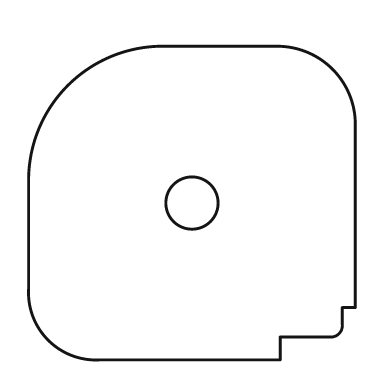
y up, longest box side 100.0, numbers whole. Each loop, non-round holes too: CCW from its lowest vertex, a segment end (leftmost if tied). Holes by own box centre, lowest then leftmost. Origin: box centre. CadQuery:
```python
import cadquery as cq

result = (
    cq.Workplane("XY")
    .moveTo(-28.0, -48.0)
    .lineTo(27.0, -48.0)
    .lineTo(27.0, -41.0)
    .lineTo(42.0, -41.0)
    .threePointArc((45.0, -40.0), (46.0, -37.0))
    .lineTo(46.0, -32.0)
    .lineTo(50.0, -32.0)
    .lineTo(50.0, 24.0)
    .threePointArc((43.0, 41.0), (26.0, 48.0))
    .lineTo(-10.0, 48.0)
    .threePointArc((-38.0, 36.0), (-50.0, 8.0))
    .lineTo(-50.0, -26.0)
    .threePointArc((-44.0, -42.0), (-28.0, -48.0))
    .close()
    .moveTo(0.0, 0.0)
    .circle(8.0)
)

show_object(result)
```